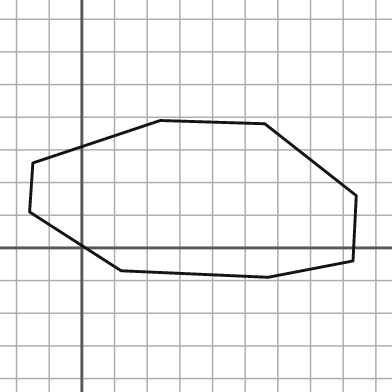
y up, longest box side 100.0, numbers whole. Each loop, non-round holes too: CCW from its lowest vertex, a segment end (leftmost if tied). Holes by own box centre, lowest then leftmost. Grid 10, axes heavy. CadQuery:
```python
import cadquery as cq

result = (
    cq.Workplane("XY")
    .moveTo(57.0, -9.0)
    .lineTo(83.0, -4.0)
    .lineTo(84.0, 16.0)
    .lineTo(56.0, 38.0)
    .lineTo(24.0, 39.0)
    .lineTo(-15.0, 26.0)
    .lineTo(-16.0, 11.0)
    .lineTo(12.0, -7.0)
    .close()
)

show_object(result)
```